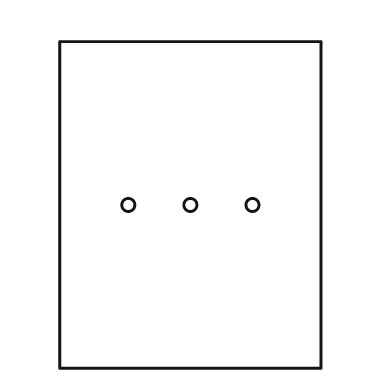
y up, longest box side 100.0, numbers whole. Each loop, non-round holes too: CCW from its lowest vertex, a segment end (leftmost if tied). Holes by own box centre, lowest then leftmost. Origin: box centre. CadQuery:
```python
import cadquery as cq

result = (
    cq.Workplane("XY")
    .moveTo(-40.0, -50.0)
    .lineTo(40.0, -50.0)
    .lineTo(40.0, 50.0)
    .lineTo(-40.0, 50.0)
    .close()
    .moveTo(-19.0, 0.0)
    .circle(2.0)
    .moveTo(0.0, 0.0)
    .circle(2.0)
    .moveTo(19.0, 0.0)
    .circle(2.0)
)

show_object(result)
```